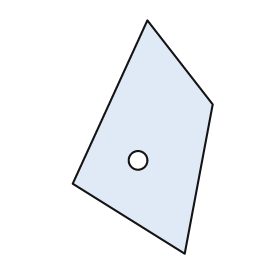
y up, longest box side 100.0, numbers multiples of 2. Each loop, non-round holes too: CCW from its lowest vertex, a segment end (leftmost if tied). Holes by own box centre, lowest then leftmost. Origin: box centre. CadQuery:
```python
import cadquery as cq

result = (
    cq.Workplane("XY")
    .moveTo(18.0, -50.0)
    .lineTo(30.0, 14.0)
    .lineTo(2.0, 50.0)
    .lineTo(-30.0, -20.0)
    .close()
    .moveTo(-2.0, -10.0)
    .circle(4.0)
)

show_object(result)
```